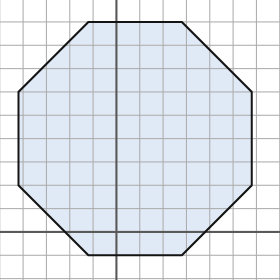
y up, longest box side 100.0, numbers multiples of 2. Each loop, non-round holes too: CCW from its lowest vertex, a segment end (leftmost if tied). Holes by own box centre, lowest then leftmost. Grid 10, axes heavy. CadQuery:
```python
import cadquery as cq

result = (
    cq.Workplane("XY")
    .moveTo(-12.0, -10.0)
    .lineTo(28.0, -10.0)
    .lineTo(58.0, 20.0)
    .lineTo(58.0, 60.0)
    .lineTo(28.0, 90.0)
    .lineTo(-12.0, 90.0)
    .lineTo(-42.0, 60.0)
    .lineTo(-42.0, 20.0)
    .close()
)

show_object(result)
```